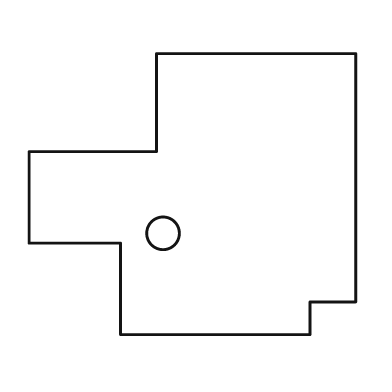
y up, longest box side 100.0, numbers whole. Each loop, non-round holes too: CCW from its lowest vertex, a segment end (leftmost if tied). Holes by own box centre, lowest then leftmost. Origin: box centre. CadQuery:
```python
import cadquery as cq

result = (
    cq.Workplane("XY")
    .moveTo(-22.0, -43.0)
    .lineTo(36.0, -43.0)
    .lineTo(36.0, -33.0)
    .lineTo(50.0, -33.0)
    .lineTo(50.0, 43.0)
    .lineTo(-11.0, 43.0)
    .lineTo(-11.0, 13.0)
    .lineTo(-50.0, 13.0)
    .lineTo(-50.0, -15.0)
    .lineTo(-22.0, -15.0)
    .close()
    .moveTo(-9.0, -12.0)
    .circle(5.0)
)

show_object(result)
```